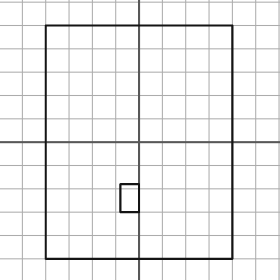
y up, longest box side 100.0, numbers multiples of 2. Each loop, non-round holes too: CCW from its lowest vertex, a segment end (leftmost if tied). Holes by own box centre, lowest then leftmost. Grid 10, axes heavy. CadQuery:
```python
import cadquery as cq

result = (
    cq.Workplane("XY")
    .moveTo(-40.0, -50.0)
    .lineTo(40.0, -50.0)
    .lineTo(40.0, 50.0)
    .lineTo(-40.0, 50.0)
    .close()
    .moveTo(-8.0, -30.0)
    .lineTo(0.0, -30.0)
    .lineTo(0.0, -18.0)
    .lineTo(-8.0, -18.0)
    .close()
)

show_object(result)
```